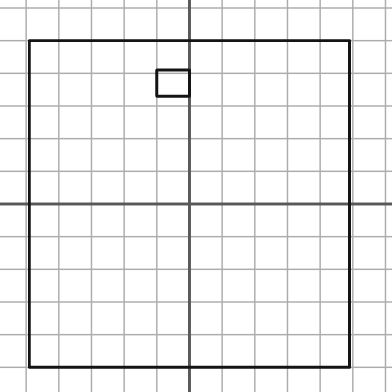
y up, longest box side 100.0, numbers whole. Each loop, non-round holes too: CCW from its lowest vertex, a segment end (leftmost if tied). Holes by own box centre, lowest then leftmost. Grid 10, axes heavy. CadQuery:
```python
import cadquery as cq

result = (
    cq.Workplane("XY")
    .moveTo(-49.0, -50.0)
    .lineTo(49.0, -50.0)
    .lineTo(49.0, 50.0)
    .lineTo(-49.0, 50.0)
    .close()
    .moveTo(-10.0, 33.0)
    .lineTo(0.0, 33.0)
    .lineTo(0.0, 41.0)
    .lineTo(-10.0, 41.0)
    .close()
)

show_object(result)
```